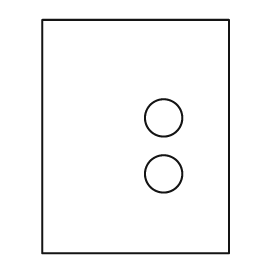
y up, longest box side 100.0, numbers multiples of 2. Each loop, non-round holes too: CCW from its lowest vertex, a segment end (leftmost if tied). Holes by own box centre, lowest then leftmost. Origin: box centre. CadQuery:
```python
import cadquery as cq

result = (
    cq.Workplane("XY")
    .moveTo(-40.0, -50.0)
    .lineTo(40.0, -50.0)
    .lineTo(40.0, 50.0)
    .lineTo(-40.0, 50.0)
    .close()
    .moveTo(12.0, -16.0)
    .circle(8.0)
    .moveTo(12.0, 8.0)
    .circle(8.0)
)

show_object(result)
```